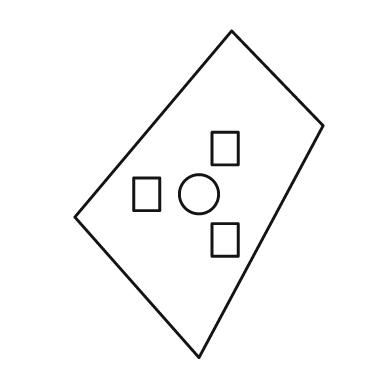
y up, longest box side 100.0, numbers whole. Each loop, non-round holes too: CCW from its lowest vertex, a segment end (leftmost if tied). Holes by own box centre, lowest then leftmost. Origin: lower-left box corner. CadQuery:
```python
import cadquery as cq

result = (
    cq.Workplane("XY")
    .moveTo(38.0, 0.0)
    .lineTo(76.0, 71.0)
    .lineTo(48.0, 100.0)
    .lineTo(0.0, 43.0)
    .close()
    .moveTo(42.0, 31.0)
    .lineTo(50.0, 31.0)
    .lineTo(50.0, 41.0)
    .lineTo(42.0, 41.0)
    .close()
    .moveTo(18.0, 45.0)
    .lineTo(26.0, 45.0)
    .lineTo(26.0, 55.0)
    .lineTo(18.0, 55.0)
    .close()
    .moveTo(38.0, 50.0)
    .circle(6.0)
    .moveTo(42.0, 59.0)
    .lineTo(50.0, 59.0)
    .lineTo(50.0, 69.0)
    .lineTo(42.0, 69.0)
    .close()
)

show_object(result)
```